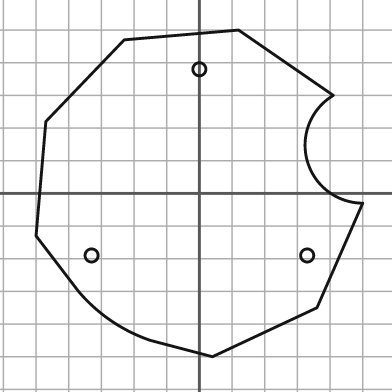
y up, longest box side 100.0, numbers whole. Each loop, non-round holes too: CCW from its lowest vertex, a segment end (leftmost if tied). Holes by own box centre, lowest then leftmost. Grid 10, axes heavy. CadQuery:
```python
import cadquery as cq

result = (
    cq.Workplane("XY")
    .moveTo(4.0, -50.0)
    .lineTo(36.0, -35.0)
    .lineTo(50.0, -3.0)
    .threePointArc((33.0, 10.0), (41.0, 30.0))
    .lineTo(12.0, 50.0)
    .lineTo(-23.0, 47.0)
    .lineTo(-47.0, 22.0)
    .lineTo(-50.0, -13.0)
    .lineTo(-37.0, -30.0)
    .threePointArc((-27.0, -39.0), (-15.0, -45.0))
    .close()
    .moveTo(-33.0, -19.0)
    .circle(2.0)
    .moveTo(33.0, -19.0)
    .circle(2.0)
    .moveTo(0.0, 38.0)
    .circle(2.0)
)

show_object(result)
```